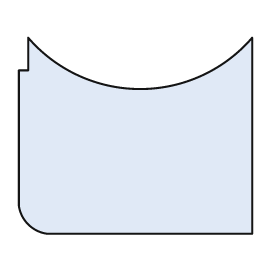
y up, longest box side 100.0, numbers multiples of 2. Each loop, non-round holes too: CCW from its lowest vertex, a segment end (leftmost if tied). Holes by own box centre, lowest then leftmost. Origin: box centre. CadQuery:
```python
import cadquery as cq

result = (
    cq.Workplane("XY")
    .moveTo(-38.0, -42.0)
    .lineTo(50.0, -42.0)
    .lineTo(50.0, 42.0)
    .threePointArc((2.0, 20.0), (-46.0, 42.0))
    .lineTo(-46.0, 28.0)
    .lineTo(-50.0, 28.0)
    .lineTo(-50.0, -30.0)
    .threePointArc((-46.0, -38.0), (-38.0, -42.0))
    .close()
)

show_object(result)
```